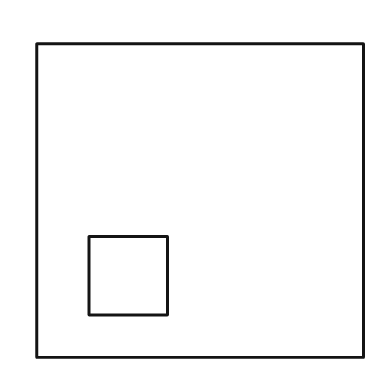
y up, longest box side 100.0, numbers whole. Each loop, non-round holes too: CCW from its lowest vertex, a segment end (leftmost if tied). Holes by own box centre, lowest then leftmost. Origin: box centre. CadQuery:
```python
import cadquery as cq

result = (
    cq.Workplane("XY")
    .moveTo(-50.0, -48.0)
    .lineTo(50.0, -48.0)
    .lineTo(50.0, 48.0)
    .lineTo(-50.0, 48.0)
    .close()
    .moveTo(-34.0, -35.0)
    .lineTo(-10.0, -35.0)
    .lineTo(-10.0, -11.0)
    .lineTo(-34.0, -11.0)
    .close()
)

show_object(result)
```